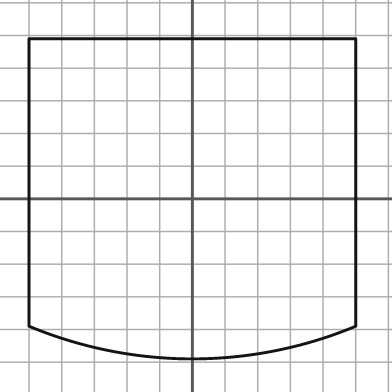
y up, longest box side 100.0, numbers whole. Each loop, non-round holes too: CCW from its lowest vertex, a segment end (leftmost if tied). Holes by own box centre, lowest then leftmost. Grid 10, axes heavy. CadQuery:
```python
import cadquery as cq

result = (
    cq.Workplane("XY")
    .moveTo(-50.0, -39.0)
    .threePointArc((0.0, -49.0), (50.0, -39.0))
    .lineTo(50.0, 49.0)
    .lineTo(-50.0, 49.0)
    .close()
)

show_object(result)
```